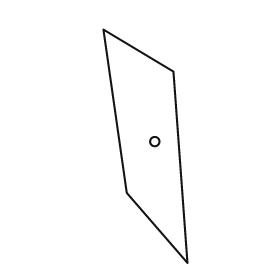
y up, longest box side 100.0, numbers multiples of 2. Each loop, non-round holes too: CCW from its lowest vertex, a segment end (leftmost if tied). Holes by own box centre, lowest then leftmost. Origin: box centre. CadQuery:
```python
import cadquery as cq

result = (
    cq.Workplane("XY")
    .moveTo(18.0, -50.0)
    .lineTo(12.0, 32.0)
    .lineTo(-18.0, 50.0)
    .lineTo(-8.0, -20.0)
    .close()
    .moveTo(4.0, 2.0)
    .circle(2.0)
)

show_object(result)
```